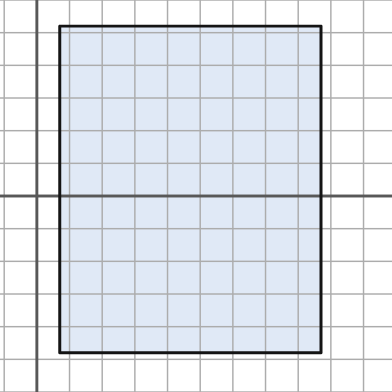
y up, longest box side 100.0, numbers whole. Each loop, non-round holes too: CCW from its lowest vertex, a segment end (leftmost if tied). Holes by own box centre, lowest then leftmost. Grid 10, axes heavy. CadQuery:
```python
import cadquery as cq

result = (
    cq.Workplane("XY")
    .moveTo(7.0, -48.0)
    .lineTo(87.0, -48.0)
    .lineTo(87.0, 52.0)
    .lineTo(7.0, 52.0)
    .close()
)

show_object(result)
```